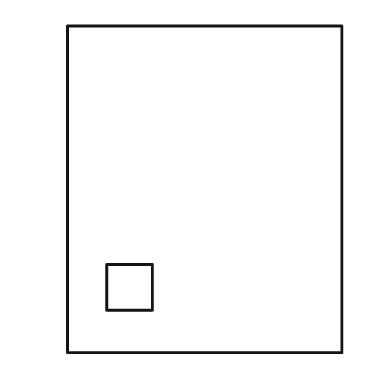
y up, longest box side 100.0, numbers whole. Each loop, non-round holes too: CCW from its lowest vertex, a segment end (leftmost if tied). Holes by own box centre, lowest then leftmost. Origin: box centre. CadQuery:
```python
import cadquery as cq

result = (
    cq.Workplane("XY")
    .moveTo(-42.0, -50.0)
    .lineTo(42.0, -50.0)
    .lineTo(42.0, 50.0)
    .lineTo(-42.0, 50.0)
    .close()
    .moveTo(-30.0, -37.0)
    .lineTo(-16.0, -37.0)
    .lineTo(-16.0, -23.0)
    .lineTo(-30.0, -23.0)
    .close()
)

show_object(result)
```